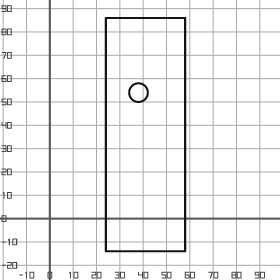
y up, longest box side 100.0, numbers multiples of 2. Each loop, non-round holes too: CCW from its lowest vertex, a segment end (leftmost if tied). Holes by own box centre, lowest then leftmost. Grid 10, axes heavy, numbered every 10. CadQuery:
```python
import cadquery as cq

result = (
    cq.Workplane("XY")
    .moveTo(24.0, -14.0)
    .lineTo(58.0, -14.0)
    .lineTo(58.0, 86.0)
    .lineTo(24.0, 86.0)
    .close()
    .moveTo(38.0, 54.0)
    .circle(4.0)
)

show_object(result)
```